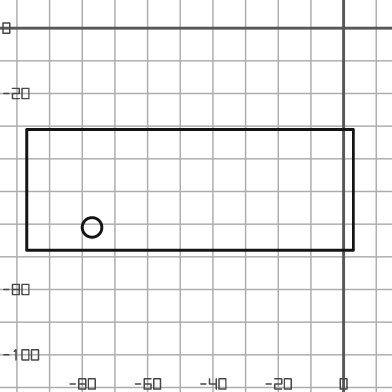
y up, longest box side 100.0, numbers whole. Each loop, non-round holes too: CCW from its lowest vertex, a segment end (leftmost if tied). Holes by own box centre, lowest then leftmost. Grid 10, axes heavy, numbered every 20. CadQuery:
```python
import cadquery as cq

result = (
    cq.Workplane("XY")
    .moveTo(-97.0, -68.0)
    .lineTo(3.0, -68.0)
    .lineTo(3.0, -31.0)
    .lineTo(-97.0, -31.0)
    .close()
    .moveTo(-77.0, -61.0)
    .circle(3.0)
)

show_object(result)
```